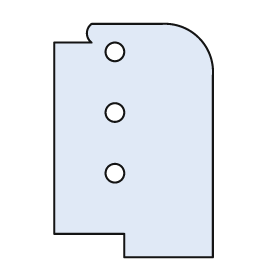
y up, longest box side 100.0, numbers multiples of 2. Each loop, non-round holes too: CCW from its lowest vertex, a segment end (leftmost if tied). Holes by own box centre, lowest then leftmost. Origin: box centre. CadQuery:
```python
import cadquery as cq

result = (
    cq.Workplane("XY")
    .moveTo(-4.0, -50.0)
    .lineTo(34.0, -50.0)
    .lineTo(34.0, 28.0)
    .threePointArc((28.0, 44.0), (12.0, 50.0))
    .lineTo(-18.0, 50.0)
    .threePointArc((-20.0, 46.0), (-18.0, 42.0))
    .lineTo(-34.0, 42.0)
    .lineTo(-34.0, -40.0)
    .lineTo(-4.0, -40.0)
    .close()
    .moveTo(-8.0, -14.0)
    .circle(4.0)
    .moveTo(-8.0, 12.0)
    .circle(4.0)
    .moveTo(-8.0, 38.0)
    .circle(4.0)
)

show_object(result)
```